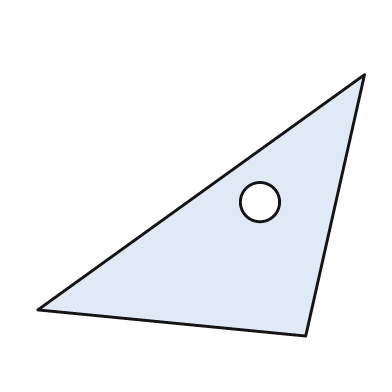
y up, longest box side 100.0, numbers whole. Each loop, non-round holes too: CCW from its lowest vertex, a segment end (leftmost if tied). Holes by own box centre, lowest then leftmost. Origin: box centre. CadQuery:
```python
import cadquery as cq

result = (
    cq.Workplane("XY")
    .moveTo(32.0, -40.0)
    .lineTo(50.0, 40.0)
    .lineTo(-50.0, -32.0)
    .close()
    .moveTo(18.0, 1.0)
    .circle(6.0)
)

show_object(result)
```